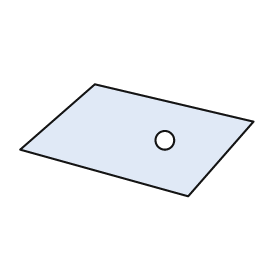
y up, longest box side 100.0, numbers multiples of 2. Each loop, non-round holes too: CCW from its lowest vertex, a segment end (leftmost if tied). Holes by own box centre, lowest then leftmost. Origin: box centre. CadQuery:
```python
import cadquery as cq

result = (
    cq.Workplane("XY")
    .moveTo(22.0, -24.0)
    .lineTo(50.0, 8.0)
    .lineTo(-18.0, 24.0)
    .lineTo(-50.0, -4.0)
    .close()
    .moveTo(12.0, 0.0)
    .circle(4.0)
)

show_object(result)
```